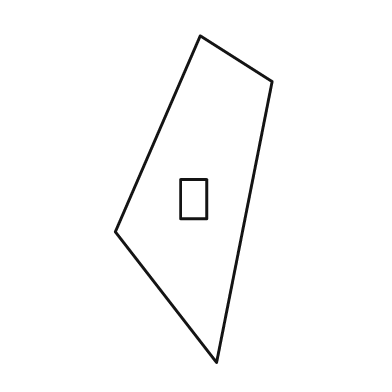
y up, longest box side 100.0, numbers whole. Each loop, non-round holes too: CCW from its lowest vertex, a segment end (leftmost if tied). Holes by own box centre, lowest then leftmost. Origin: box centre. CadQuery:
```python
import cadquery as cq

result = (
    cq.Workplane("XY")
    .moveTo(7.0, -50.0)
    .lineTo(24.0, 36.0)
    .lineTo(2.0, 50.0)
    .lineTo(-24.0, -10.0)
    .close()
    .moveTo(-4.0, -6.0)
    .lineTo(4.0, -6.0)
    .lineTo(4.0, 6.0)
    .lineTo(-4.0, 6.0)
    .close()
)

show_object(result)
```